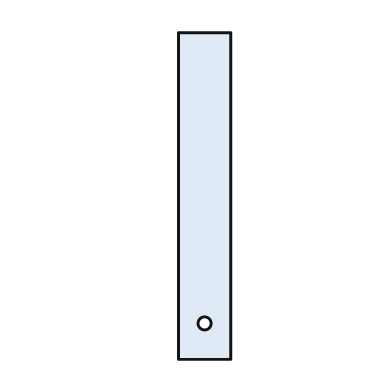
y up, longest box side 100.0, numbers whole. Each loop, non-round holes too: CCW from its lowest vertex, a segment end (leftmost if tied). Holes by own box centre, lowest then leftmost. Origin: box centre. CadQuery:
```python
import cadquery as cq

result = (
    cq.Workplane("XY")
    .moveTo(-8.0, -50.0)
    .lineTo(8.0, -50.0)
    .lineTo(8.0, 50.0)
    .lineTo(-8.0, 50.0)
    .close()
    .moveTo(0.0, -39.0)
    .circle(2.0)
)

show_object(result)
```